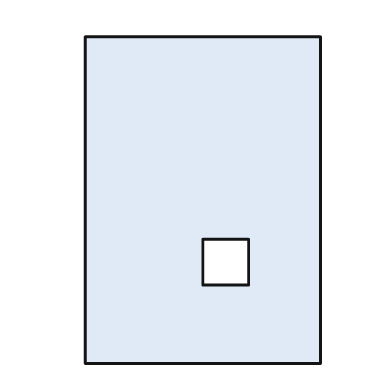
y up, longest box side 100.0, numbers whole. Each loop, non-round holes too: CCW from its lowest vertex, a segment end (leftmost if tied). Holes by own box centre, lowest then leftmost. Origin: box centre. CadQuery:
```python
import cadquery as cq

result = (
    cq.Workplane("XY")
    .moveTo(-36.0, -50.0)
    .lineTo(36.0, -50.0)
    .lineTo(36.0, 50.0)
    .lineTo(-36.0, 50.0)
    .close()
    .moveTo(0.0, -26.0)
    .lineTo(14.0, -26.0)
    .lineTo(14.0, -12.0)
    .lineTo(0.0, -12.0)
    .close()
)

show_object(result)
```